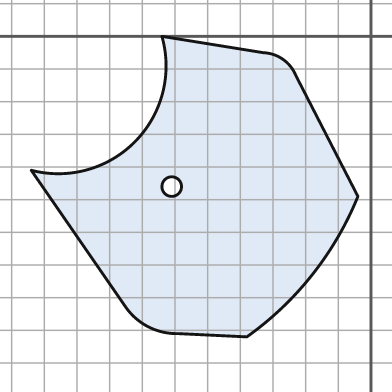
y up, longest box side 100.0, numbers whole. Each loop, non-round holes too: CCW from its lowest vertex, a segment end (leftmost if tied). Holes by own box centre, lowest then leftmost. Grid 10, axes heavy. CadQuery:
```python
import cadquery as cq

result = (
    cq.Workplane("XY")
    .moveTo(-38.0, -92.0)
    .threePointArc((-18.0, -73.0), (-4.0, -49.0))
    .lineTo(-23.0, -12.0)
    .threePointArc((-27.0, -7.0), (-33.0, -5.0))
    .lineTo(-64.0, 0.0)
    .threePointArc((-72.0, -32.0), (-104.0, -41.0))
    .lineTo(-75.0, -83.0)
    .threePointArc((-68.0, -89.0), (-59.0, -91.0))
    .close()
    .moveTo(-61.0, -46.0)
    .circle(3.0)
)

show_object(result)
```